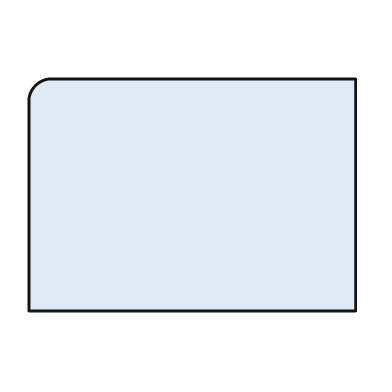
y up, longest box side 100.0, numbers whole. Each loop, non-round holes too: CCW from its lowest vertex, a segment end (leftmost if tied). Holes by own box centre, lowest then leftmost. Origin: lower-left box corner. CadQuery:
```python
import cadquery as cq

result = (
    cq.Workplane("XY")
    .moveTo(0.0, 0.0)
    .lineTo(100.0, 0.0)
    .lineTo(100.0, 71.0)
    .lineTo(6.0, 71.0)
    .threePointArc((2.0, 69.0), (0.0, 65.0))
    .close()
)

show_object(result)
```